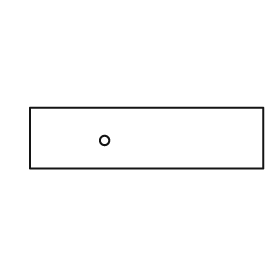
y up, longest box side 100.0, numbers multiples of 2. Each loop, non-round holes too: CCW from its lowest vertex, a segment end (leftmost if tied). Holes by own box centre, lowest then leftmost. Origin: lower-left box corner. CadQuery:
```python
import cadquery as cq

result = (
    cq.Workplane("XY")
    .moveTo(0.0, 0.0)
    .lineTo(100.0, 0.0)
    .lineTo(100.0, 26.0)
    .lineTo(0.0, 26.0)
    .close()
    .moveTo(32.0, 12.0)
    .circle(2.0)
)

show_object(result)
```